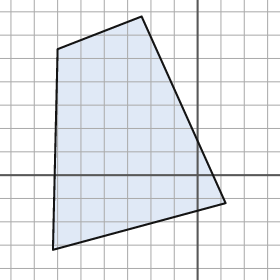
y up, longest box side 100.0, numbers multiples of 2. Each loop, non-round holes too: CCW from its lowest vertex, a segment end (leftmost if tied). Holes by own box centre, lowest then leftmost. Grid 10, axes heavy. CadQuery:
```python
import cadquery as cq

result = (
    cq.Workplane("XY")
    .moveTo(-62.0, -32.0)
    .lineTo(12.0, -12.0)
    .lineTo(-24.0, 68.0)
    .lineTo(-60.0, 54.0)
    .close()
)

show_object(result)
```